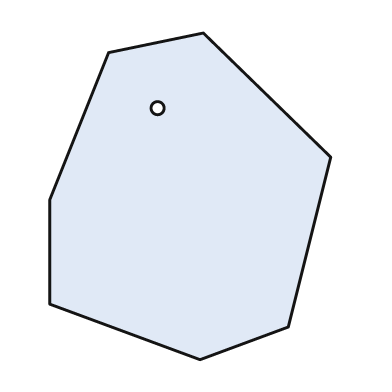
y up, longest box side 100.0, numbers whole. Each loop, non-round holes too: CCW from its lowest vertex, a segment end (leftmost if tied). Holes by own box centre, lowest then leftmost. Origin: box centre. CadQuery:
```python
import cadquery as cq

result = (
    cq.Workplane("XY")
    .moveTo(3.0, -50.0)
    .lineTo(30.0, -40.0)
    .lineTo(43.0, 12.0)
    .lineTo(4.0, 50.0)
    .lineTo(-25.0, 44.0)
    .lineTo(-43.0, -1.0)
    .lineTo(-43.0, -33.0)
    .close()
    .moveTo(-10.0, 27.0)
    .circle(2.0)
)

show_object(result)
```